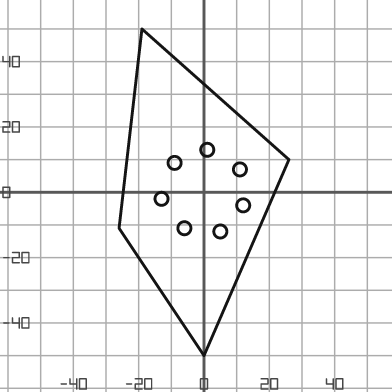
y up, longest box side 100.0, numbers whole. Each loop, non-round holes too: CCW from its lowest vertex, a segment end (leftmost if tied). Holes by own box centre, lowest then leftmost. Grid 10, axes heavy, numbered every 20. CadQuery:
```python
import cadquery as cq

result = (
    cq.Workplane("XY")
    .moveTo(0.0, -50.0)
    .lineTo(26.0, 10.0)
    .lineTo(-19.0, 50.0)
    .lineTo(-26.0, -11.0)
    .close()
    .moveTo(5.0, -12.0)
    .circle(2.0)
    .moveTo(-6.0, -11.0)
    .circle(2.0)
    .moveTo(12.0, -4.0)
    .circle(2.0)
    .moveTo(-13.0, -2.0)
    .circle(2.0)
    .moveTo(11.0, 7.0)
    .circle(2.0)
    .moveTo(-9.0, 9.0)
    .circle(2.0)
    .moveTo(1.0, 13.0)
    .circle(2.0)
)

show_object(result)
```